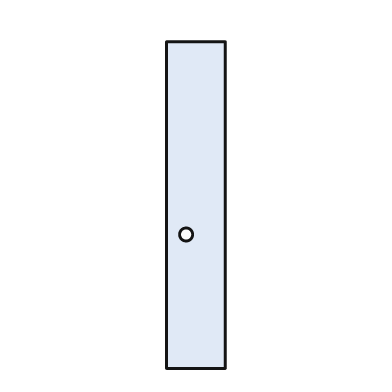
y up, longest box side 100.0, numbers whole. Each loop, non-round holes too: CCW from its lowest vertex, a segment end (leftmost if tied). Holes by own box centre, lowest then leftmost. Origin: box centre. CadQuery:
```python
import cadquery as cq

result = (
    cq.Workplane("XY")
    .moveTo(-9.0, -50.0)
    .lineTo(9.0, -50.0)
    .lineTo(9.0, 50.0)
    .lineTo(-9.0, 50.0)
    .close()
    .moveTo(-3.0, -9.0)
    .circle(2.0)
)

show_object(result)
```